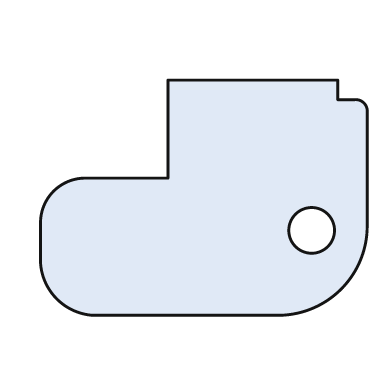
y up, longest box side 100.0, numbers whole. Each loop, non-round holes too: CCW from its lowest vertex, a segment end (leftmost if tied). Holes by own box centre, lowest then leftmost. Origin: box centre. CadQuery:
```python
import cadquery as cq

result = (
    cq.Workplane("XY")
    .moveTo(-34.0, -36.0)
    .lineTo(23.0, -36.0)
    .threePointArc((42.0, -28.0), (50.0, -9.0))
    .lineTo(50.0, 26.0)
    .threePointArc((49.0, 29.0), (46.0, 30.0))
    .lineTo(41.0, 30.0)
    .lineTo(41.0, 36.0)
    .lineTo(-11.0, 36.0)
    .lineTo(-11.0, 6.0)
    .lineTo(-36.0, 6.0)
    .threePointArc((-46.0, 2.0), (-50.0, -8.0))
    .lineTo(-50.0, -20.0)
    .threePointArc((-45.0, -31.0), (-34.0, -36.0))
    .close()
    .moveTo(33.0, -10.0)
    .circle(7.0)
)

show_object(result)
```